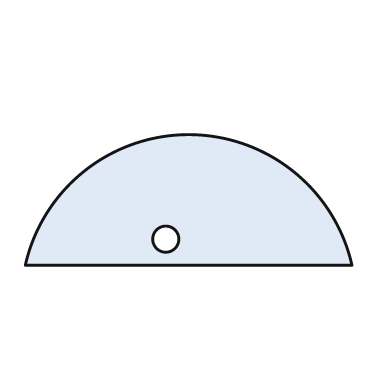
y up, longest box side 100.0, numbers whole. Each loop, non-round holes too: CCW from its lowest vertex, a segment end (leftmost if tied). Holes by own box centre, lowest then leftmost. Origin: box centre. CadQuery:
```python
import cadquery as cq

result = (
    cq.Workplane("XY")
    .moveTo(-50.0, -20.0)
    .lineTo(50.0, -20.0)
    .threePointArc((0.0, 20.0), (-50.0, -20.0))
    .close()
    .moveTo(-7.0, -12.0)
    .circle(4.0)
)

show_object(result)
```